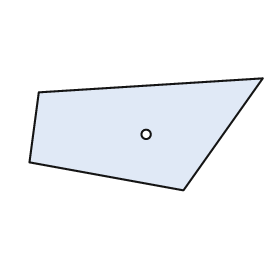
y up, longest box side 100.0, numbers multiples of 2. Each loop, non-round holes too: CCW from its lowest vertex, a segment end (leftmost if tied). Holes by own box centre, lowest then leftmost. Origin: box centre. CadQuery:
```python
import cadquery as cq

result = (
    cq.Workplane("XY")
    .moveTo(16.0, -24.0)
    .lineTo(50.0, 24.0)
    .lineTo(-46.0, 18.0)
    .lineTo(-50.0, -12.0)
    .close()
    .moveTo(0.0, 0.0)
    .circle(2.0)
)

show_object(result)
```